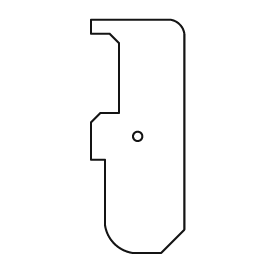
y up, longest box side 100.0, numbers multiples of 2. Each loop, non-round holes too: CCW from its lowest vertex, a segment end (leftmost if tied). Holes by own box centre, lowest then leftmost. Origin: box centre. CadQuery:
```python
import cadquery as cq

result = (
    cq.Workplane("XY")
    .moveTo(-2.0, -50.0)
    .lineTo(10.0, -50.0)
    .lineTo(20.0, -40.0)
    .lineTo(20.0, 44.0)
    .threePointArc((18.0, 48.0), (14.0, 50.0))
    .lineTo(-20.0, 50.0)
    .lineTo(-20.0, 44.0)
    .lineTo(-12.0, 44.0)
    .lineTo(-8.0, 40.0)
    .lineTo(-8.0, 10.0)
    .lineTo(-16.0, 10.0)
    .lineTo(-20.0, 6.0)
    .lineTo(-20.0, -10.0)
    .lineTo(-14.0, -10.0)
    .lineTo(-14.0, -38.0)
    .threePointArc((-10.0, -46.0), (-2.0, -50.0))
    .close()
    .moveTo(0.0, 0.0)
    .circle(2.0)
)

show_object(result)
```